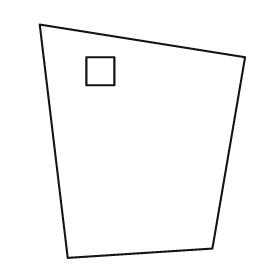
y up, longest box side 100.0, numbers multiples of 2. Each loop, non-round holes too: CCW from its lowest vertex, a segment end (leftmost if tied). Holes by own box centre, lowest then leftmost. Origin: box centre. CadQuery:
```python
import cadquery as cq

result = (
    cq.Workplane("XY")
    .moveTo(-32.0, -50.0)
    .lineTo(30.0, -46.0)
    .lineTo(44.0, 36.0)
    .lineTo(-44.0, 50.0)
    .close()
    .moveTo(-24.0, 24.0)
    .lineTo(-12.0, 24.0)
    .lineTo(-12.0, 36.0)
    .lineTo(-24.0, 36.0)
    .close()
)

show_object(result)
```